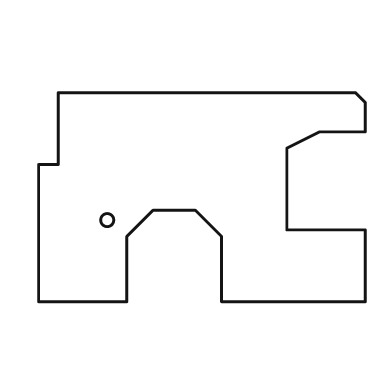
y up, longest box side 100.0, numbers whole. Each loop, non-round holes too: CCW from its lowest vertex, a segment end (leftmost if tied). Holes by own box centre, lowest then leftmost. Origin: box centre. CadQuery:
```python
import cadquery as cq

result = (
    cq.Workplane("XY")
    .moveTo(-50.0, -32.0)
    .lineTo(-23.0, -32.0)
    .lineTo(-23.0, -12.0)
    .lineTo(-15.0, -4.0)
    .lineTo(-2.0, -4.0)
    .lineTo(6.0, -12.0)
    .lineTo(6.0, -32.0)
    .lineTo(50.0, -32.0)
    .lineTo(50.0, -10.0)
    .lineTo(26.0, -10.0)
    .lineTo(26.0, 15.0)
    .lineTo(36.0, 20.0)
    .lineTo(50.0, 20.0)
    .lineTo(50.0, 29.0)
    .lineTo(47.0, 32.0)
    .lineTo(-44.0, 32.0)
    .lineTo(-44.0, 10.0)
    .lineTo(-50.0, 10.0)
    .close()
    .moveTo(-29.0, -7.0)
    .circle(2.0)
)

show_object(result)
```